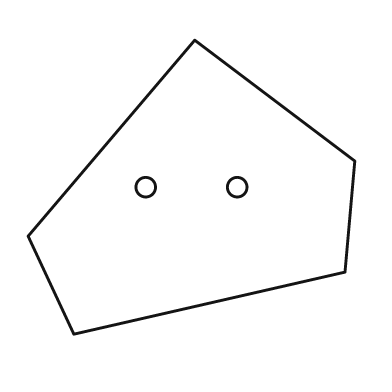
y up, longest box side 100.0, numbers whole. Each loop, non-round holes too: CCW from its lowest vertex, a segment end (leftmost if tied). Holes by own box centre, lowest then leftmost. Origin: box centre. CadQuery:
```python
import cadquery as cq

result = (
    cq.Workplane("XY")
    .moveTo(-36.0, -45.0)
    .lineTo(47.0, -26.0)
    .lineTo(50.0, 8.0)
    .lineTo(1.0, 45.0)
    .lineTo(-50.0, -15.0)
    .close()
    .moveTo(-14.0, 0.0)
    .circle(3.0)
    .moveTo(14.0, 0.0)
    .circle(3.0)
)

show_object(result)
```